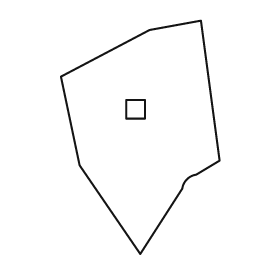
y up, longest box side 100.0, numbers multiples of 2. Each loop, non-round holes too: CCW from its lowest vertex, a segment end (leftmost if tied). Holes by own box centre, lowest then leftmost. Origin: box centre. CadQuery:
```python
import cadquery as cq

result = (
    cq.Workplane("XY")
    .moveTo(0.0, -50.0)
    .lineTo(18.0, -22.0)
    .threePointArc((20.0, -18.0), (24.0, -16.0))
    .lineTo(34.0, -10.0)
    .lineTo(26.0, 50.0)
    .lineTo(4.0, 46.0)
    .lineTo(-34.0, 26.0)
    .lineTo(-26.0, -12.0)
    .close()
    .moveTo(-6.0, 8.0)
    .lineTo(2.0, 8.0)
    .lineTo(2.0, 16.0)
    .lineTo(-6.0, 16.0)
    .close()
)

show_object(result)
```